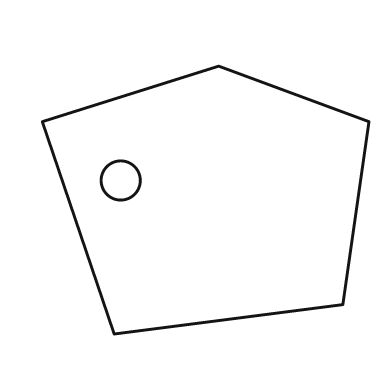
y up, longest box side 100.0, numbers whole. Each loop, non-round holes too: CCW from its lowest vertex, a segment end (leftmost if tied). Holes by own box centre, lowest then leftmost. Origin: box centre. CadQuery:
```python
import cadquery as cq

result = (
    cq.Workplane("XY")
    .moveTo(-28.0, -41.0)
    .lineTo(42.0, -32.0)
    .lineTo(50.0, 24.0)
    .lineTo(4.0, 41.0)
    .lineTo(-50.0, 24.0)
    .close()
    .moveTo(-26.0, 6.0)
    .circle(6.0)
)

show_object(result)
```